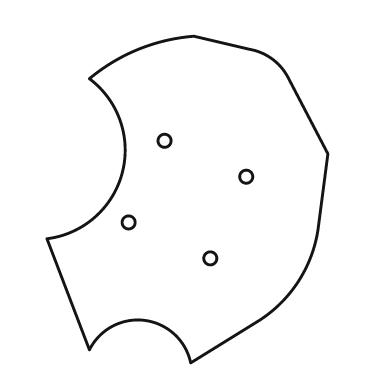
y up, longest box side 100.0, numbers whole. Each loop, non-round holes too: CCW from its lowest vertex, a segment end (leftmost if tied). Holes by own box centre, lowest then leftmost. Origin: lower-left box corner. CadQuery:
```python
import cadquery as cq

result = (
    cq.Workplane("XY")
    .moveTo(44.0, 0.0)
    .lineTo(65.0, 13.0)
    .threePointArc((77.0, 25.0), (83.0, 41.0))
    .lineTo(86.0, 64.0)
    .lineTo(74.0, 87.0)
    .threePointArc((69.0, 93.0), (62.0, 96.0))
    .lineTo(45.0, 100.0)
    .threePointArc((28.0, 96.0), (13.0, 87.0))
    .threePointArc((23.0, 58.0), (0.0, 38.0))
    .lineTo(13.0, 4.0)
    .threePointArc((30.0, 13.0), (44.0, 0.0))
    .close()
    .moveTo(50.0, 32.0)
    .circle(2.0)
    .moveTo(25.0, 43.0)
    .circle(2.0)
    .moveTo(61.0, 57.0)
    .circle(2.0)
    .moveTo(36.0, 68.0)
    .circle(2.0)
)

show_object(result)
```